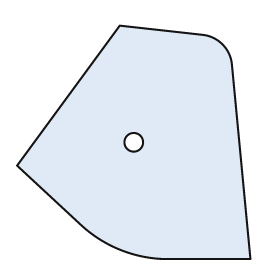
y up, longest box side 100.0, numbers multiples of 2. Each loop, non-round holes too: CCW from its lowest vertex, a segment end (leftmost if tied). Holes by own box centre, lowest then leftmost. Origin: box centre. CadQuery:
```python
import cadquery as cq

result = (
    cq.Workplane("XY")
    .moveTo(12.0, -50.0)
    .lineTo(50.0, -50.0)
    .lineTo(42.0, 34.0)
    .threePointArc((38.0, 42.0), (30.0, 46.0))
    .lineTo(-6.0, 50.0)
    .lineTo(-50.0, -10.0)
    .lineTo(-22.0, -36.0)
    .threePointArc((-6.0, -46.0), (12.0, -50.0))
    .close()
    .moveTo(0.0, 0.0)
    .circle(4.0)
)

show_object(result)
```